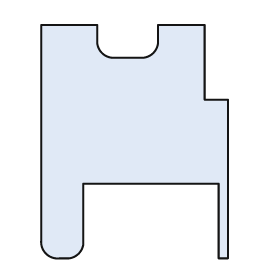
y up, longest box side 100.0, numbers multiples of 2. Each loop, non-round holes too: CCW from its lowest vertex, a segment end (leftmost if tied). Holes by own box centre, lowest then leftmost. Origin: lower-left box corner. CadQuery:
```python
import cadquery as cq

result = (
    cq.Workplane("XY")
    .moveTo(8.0, 0.0)
    .lineTo(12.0, 0.0)
    .threePointArc((16.0, 2.0), (18.0, 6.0))
    .lineTo(18.0, 32.0)
    .lineTo(76.0, 32.0)
    .lineTo(76.0, 0.0)
    .lineTo(80.0, 0.0)
    .lineTo(80.0, 68.0)
    .lineTo(70.0, 68.0)
    .lineTo(70.0, 100.0)
    .lineTo(50.0, 100.0)
    .lineTo(50.0, 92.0)
    .threePointArc((48.0, 88.0), (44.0, 86.0))
    .lineTo(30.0, 86.0)
    .threePointArc((26.0, 88.0), (24.0, 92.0))
    .lineTo(24.0, 100.0)
    .lineTo(0.0, 100.0)
    .lineTo(0.0, 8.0)
    .threePointArc((2.0, 2.0), (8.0, 0.0))
    .close()
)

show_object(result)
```